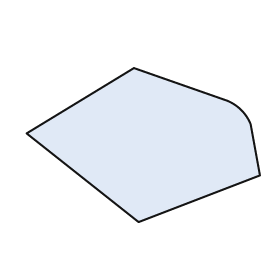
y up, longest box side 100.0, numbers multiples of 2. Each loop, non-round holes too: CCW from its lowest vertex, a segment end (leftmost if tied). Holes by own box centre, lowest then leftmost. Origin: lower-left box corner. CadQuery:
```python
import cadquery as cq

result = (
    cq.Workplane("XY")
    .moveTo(48.0, 0.0)
    .lineTo(100.0, 20.0)
    .lineTo(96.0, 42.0)
    .threePointArc((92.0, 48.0), (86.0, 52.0))
    .lineTo(46.0, 66.0)
    .lineTo(0.0, 38.0)
    .close()
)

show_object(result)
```